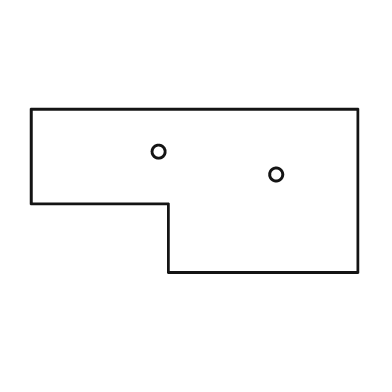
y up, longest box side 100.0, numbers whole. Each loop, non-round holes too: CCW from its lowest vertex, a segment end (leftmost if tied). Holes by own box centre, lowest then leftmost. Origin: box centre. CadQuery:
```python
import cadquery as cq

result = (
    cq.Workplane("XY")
    .moveTo(-8.0, -25.0)
    .lineTo(50.0, -25.0)
    .lineTo(50.0, 25.0)
    .lineTo(-50.0, 25.0)
    .lineTo(-50.0, -4.0)
    .lineTo(-8.0, -4.0)
    .close()
    .moveTo(25.0, 5.0)
    .circle(2.0)
    .moveTo(-11.0, 12.0)
    .circle(2.0)
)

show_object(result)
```